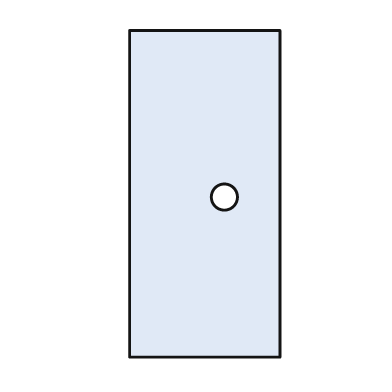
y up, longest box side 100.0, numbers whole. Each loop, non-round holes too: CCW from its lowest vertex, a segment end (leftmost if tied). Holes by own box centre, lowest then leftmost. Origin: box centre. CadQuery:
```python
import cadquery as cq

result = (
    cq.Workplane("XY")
    .moveTo(-23.0, -50.0)
    .lineTo(23.0, -50.0)
    .lineTo(23.0, 50.0)
    .lineTo(-23.0, 50.0)
    .close()
    .moveTo(6.0, -1.0)
    .circle(4.0)
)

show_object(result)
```